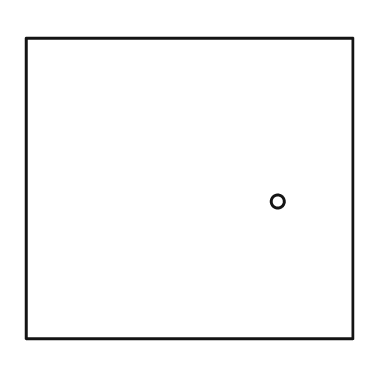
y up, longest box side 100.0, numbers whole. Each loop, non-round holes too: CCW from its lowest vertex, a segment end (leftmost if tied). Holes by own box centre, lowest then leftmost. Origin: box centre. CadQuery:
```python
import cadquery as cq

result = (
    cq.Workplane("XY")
    .moveTo(-50.0, -46.0)
    .lineTo(50.0, -46.0)
    .lineTo(50.0, 46.0)
    .lineTo(-50.0, 46.0)
    .close()
    .moveTo(27.0, -4.0)
    .circle(2.0)
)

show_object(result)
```